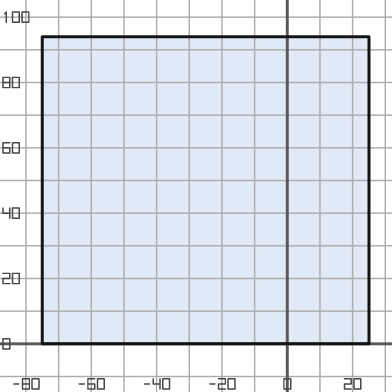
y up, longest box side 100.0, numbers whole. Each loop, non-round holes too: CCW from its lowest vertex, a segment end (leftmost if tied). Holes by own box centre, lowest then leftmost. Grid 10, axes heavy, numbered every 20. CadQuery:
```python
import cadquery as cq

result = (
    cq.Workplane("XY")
    .moveTo(-75.0, 0.0)
    .lineTo(25.0, 0.0)
    .lineTo(25.0, 94.0)
    .lineTo(-75.0, 94.0)
    .close()
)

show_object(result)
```